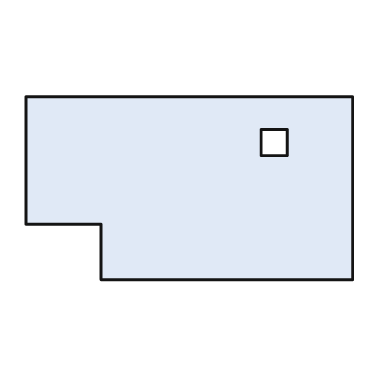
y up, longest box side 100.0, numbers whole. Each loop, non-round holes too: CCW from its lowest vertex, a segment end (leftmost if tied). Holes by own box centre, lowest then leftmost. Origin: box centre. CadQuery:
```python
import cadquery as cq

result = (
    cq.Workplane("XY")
    .moveTo(-27.0, -28.0)
    .lineTo(50.0, -28.0)
    .lineTo(50.0, 28.0)
    .lineTo(-50.0, 28.0)
    .lineTo(-50.0, -11.0)
    .lineTo(-27.0, -11.0)
    .close()
    .moveTo(22.0, 10.0)
    .lineTo(30.0, 10.0)
    .lineTo(30.0, 18.0)
    .lineTo(22.0, 18.0)
    .close()
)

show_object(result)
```